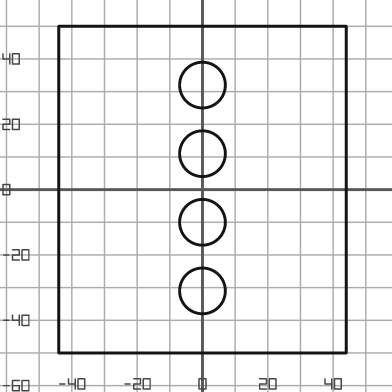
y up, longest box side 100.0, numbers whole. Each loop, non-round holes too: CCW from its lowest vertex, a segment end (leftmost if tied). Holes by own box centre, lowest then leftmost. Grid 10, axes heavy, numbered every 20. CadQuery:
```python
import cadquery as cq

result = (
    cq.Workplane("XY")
    .moveTo(-44.0, -50.0)
    .lineTo(44.0, -50.0)
    .lineTo(44.0, 50.0)
    .lineTo(-44.0, 50.0)
    .close()
    .moveTo(0.0, -31.0)
    .circle(7.0)
    .moveTo(0.0, -10.0)
    .circle(7.0)
    .moveTo(0.0, 11.0)
    .circle(7.0)
    .moveTo(0.0, 32.0)
    .circle(7.0)
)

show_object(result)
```